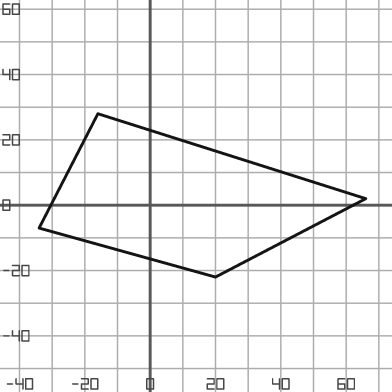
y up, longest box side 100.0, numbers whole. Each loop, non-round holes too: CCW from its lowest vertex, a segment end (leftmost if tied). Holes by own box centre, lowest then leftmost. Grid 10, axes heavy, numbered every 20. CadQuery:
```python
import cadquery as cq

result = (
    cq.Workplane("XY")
    .moveTo(20.0, -22.0)
    .lineTo(66.0, 2.0)
    .lineTo(-16.0, 28.0)
    .lineTo(-34.0, -7.0)
    .close()
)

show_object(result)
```